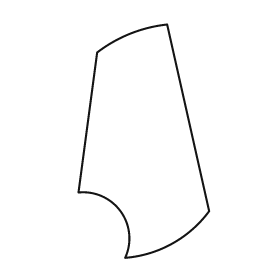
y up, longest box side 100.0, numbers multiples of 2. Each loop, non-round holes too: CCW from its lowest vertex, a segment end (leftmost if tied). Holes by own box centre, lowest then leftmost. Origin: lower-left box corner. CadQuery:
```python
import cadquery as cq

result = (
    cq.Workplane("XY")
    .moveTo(20.0, 0.0)
    .threePointArc((40.0, 6.0), (56.0, 20.0))
    .lineTo(38.0, 100.0)
    .threePointArc((22.0, 96.0), (8.0, 88.0))
    .lineTo(0.0, 28.0)
    .threePointArc((18.0, 20.0), (20.0, 0.0))
    .close()
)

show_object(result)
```